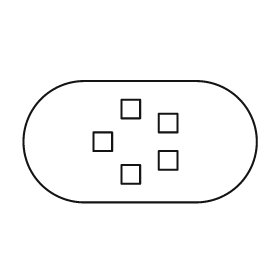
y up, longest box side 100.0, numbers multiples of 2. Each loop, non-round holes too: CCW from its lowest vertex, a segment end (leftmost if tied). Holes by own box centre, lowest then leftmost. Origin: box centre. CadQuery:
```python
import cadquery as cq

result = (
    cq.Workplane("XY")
    .moveTo(-24.0, -26.0)
    .lineTo(24.0, -26.0)
    .threePointArc((50.0, 0.0), (24.0, 26.0))
    .lineTo(-24.0, 26.0)
    .threePointArc((-50.0, 0.0), (-24.0, -26.0))
    .close()
    .moveTo(-8.0, -18.0)
    .lineTo(0.0, -18.0)
    .lineTo(0.0, -10.0)
    .lineTo(-8.0, -10.0)
    .close()
    .moveTo(8.0, -12.0)
    .lineTo(16.0, -12.0)
    .lineTo(16.0, -4.0)
    .lineTo(8.0, -4.0)
    .close()
    .moveTo(-20.0, -4.0)
    .lineTo(-12.0, -4.0)
    .lineTo(-12.0, 4.0)
    .lineTo(-20.0, 4.0)
    .close()
    .moveTo(8.0, 4.0)
    .lineTo(16.0, 4.0)
    .lineTo(16.0, 12.0)
    .lineTo(8.0, 12.0)
    .close()
    .moveTo(-8.0, 10.0)
    .lineTo(0.0, 10.0)
    .lineTo(0.0, 18.0)
    .lineTo(-8.0, 18.0)
    .close()
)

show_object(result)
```